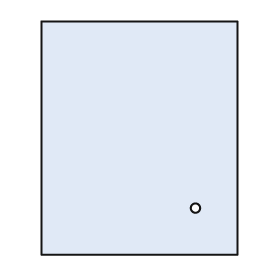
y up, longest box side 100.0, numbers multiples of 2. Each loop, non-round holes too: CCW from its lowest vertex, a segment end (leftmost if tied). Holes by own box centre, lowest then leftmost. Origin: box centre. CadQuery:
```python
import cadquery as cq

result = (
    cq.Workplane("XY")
    .moveTo(-42.0, -50.0)
    .lineTo(42.0, -50.0)
    .lineTo(42.0, 50.0)
    .lineTo(-42.0, 50.0)
    .close()
    .moveTo(24.0, -30.0)
    .circle(2.0)
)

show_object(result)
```